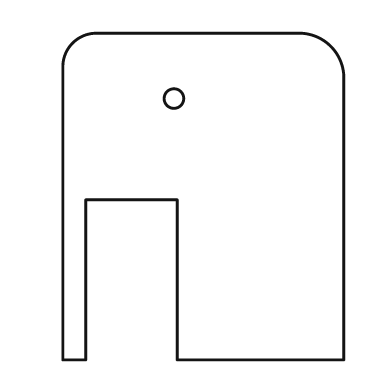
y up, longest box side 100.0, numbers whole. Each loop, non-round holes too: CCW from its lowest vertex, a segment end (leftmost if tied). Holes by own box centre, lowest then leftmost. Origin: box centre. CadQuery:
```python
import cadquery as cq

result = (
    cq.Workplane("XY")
    .moveTo(-43.0, -50.0)
    .lineTo(-36.0, -50.0)
    .lineTo(-36.0, -1.0)
    .lineTo(-8.0, -1.0)
    .lineTo(-8.0, -50.0)
    .lineTo(43.0, -50.0)
    .lineTo(43.0, 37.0)
    .threePointArc((39.0, 46.0), (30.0, 50.0))
    .lineTo(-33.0, 50.0)
    .threePointArc((-40.0, 47.0), (-43.0, 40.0))
    .close()
    .moveTo(-9.0, 30.0)
    .circle(3.0)
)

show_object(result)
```